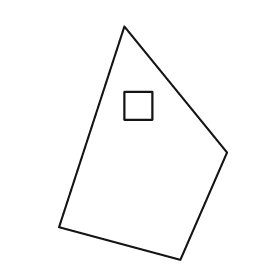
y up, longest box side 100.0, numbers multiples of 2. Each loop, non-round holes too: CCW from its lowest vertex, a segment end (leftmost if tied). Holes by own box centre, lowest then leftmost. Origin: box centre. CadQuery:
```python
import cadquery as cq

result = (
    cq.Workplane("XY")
    .moveTo(16.0, -50.0)
    .lineTo(36.0, -4.0)
    .lineTo(-8.0, 50.0)
    .lineTo(-36.0, -36.0)
    .close()
    .moveTo(-8.0, 10.0)
    .lineTo(4.0, 10.0)
    .lineTo(4.0, 22.0)
    .lineTo(-8.0, 22.0)
    .close()
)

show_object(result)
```